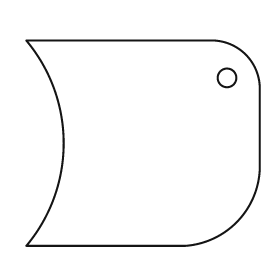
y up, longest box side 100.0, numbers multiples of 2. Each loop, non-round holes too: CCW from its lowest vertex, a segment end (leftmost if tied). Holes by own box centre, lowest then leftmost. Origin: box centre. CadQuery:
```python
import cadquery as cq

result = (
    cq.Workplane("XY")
    .moveTo(-50.0, -44.0)
    .lineTo(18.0, -44.0)
    .threePointArc((40.0, -34.0), (50.0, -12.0))
    .lineTo(50.0, 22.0)
    .threePointArc((44.0, 38.0), (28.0, 44.0))
    .lineTo(-50.0, 44.0)
    .threePointArc((-34.0, 0.0), (-50.0, -44.0))
    .close()
    .moveTo(36.0, 28.0)
    .circle(4.0)
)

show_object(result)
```